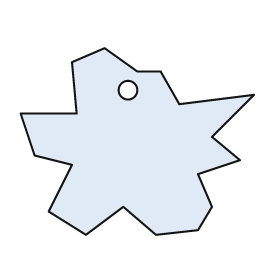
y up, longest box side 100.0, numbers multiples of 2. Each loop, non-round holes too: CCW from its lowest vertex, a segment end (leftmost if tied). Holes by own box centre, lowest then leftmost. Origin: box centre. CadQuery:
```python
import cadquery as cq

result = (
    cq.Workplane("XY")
    .moveTo(-22.0, -40.0)
    .lineTo(-6.0, -28.0)
    .lineTo(8.0, -40.0)
    .lineTo(26.0, -38.0)
    .lineTo(32.0, -28.0)
    .lineTo(26.0, -14.0)
    .lineTo(44.0, -8.0)
    .lineTo(32.0, 2.0)
    .lineTo(50.0, 20.0)
    .lineTo(18.0, 16.0)
    .lineTo(10.0, 30.0)
    .lineTo(0.0, 30.0)
    .lineTo(-14.0, 40.0)
    .lineTo(-28.0, 34.0)
    .lineTo(-26.0, 12.0)
    .lineTo(-50.0, 12.0)
    .lineTo(-44.0, -6.0)
    .lineTo(-28.0, -10.0)
    .lineTo(-38.0, -30.0)
    .close()
    .moveTo(-4.0, 22.0)
    .circle(4.0)
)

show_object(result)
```